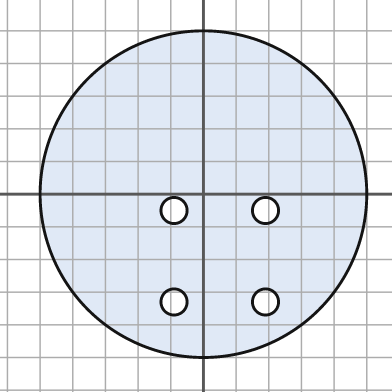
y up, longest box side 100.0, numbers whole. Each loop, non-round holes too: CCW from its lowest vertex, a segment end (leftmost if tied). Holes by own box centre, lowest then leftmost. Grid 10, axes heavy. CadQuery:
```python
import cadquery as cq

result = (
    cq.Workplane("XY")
    .moveTo(0.0, 0.0)
    .circle(50.0)
    .moveTo(-9.0, -33.0)
    .circle(4.0)
    .moveTo(19.0, -33.0)
    .circle(4.0)
    .moveTo(-9.0, -5.0)
    .circle(4.0)
    .moveTo(19.0, -5.0)
    .circle(4.0)
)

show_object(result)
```